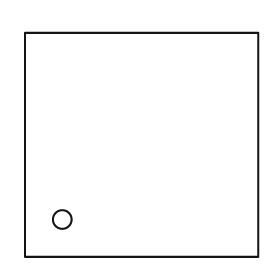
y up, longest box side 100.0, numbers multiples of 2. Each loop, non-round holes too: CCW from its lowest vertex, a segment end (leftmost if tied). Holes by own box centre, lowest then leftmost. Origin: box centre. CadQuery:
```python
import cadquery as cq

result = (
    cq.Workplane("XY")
    .moveTo(-50.0, -48.0)
    .lineTo(50.0, -48.0)
    .lineTo(50.0, 48.0)
    .lineTo(-50.0, 48.0)
    .close()
    .moveTo(-34.0, -32.0)
    .circle(4.0)
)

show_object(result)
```